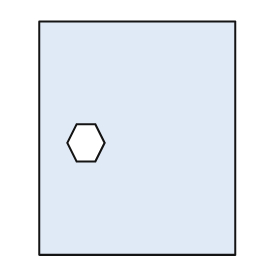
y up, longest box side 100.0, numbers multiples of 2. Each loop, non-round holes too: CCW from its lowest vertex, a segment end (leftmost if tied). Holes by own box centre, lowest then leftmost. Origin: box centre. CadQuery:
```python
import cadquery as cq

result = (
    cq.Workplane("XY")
    .moveTo(-42.0, -50.0)
    .lineTo(42.0, -50.0)
    .lineTo(42.0, 50.0)
    .lineTo(-42.0, 50.0)
    .close()
    .moveTo(-26.0, -10.0)
    .lineTo(-18.0, -10.0)
    .lineTo(-14.0, -2.0)
    .lineTo(-18.0, 6.0)
    .lineTo(-26.0, 6.0)
    .lineTo(-30.0, -2.0)
    .close()
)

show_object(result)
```